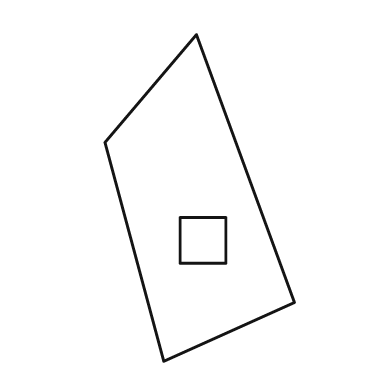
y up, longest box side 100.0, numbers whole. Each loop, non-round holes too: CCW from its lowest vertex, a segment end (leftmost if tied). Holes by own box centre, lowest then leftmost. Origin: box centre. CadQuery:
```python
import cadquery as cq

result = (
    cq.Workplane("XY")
    .moveTo(-11.0, -50.0)
    .lineTo(29.0, -32.0)
    .lineTo(-1.0, 50.0)
    .lineTo(-29.0, 17.0)
    .close()
    .moveTo(-6.0, -20.0)
    .lineTo(8.0, -20.0)
    .lineTo(8.0, -6.0)
    .lineTo(-6.0, -6.0)
    .close()
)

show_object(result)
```